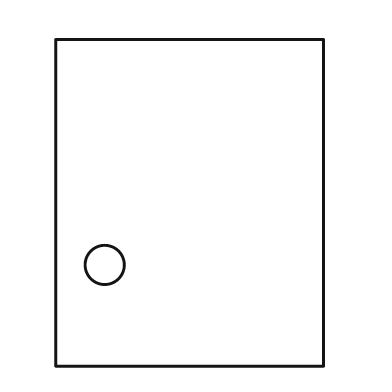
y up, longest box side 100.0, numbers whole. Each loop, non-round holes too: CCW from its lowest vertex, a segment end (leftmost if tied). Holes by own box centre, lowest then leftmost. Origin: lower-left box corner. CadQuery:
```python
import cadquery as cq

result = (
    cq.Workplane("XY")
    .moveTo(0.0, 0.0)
    .lineTo(82.0, 0.0)
    .lineTo(82.0, 100.0)
    .lineTo(0.0, 100.0)
    .close()
    .moveTo(15.0, 31.0)
    .circle(6.0)
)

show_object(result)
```